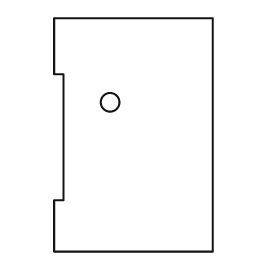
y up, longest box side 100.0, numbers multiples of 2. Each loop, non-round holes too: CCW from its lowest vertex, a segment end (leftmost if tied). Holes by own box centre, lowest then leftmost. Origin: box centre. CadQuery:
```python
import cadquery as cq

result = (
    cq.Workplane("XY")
    .moveTo(-34.0, -50.0)
    .lineTo(34.0, -50.0)
    .lineTo(34.0, 50.0)
    .lineTo(-34.0, 50.0)
    .lineTo(-34.0, 26.0)
    .lineTo(-30.0, 26.0)
    .lineTo(-30.0, -28.0)
    .lineTo(-34.0, -28.0)
    .close()
    .moveTo(-10.0, 14.0)
    .circle(4.0)
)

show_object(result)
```